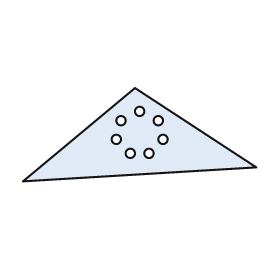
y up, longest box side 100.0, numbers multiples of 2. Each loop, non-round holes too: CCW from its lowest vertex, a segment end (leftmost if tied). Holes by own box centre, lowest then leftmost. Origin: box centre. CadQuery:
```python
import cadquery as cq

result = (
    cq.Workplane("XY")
    .moveTo(-50.0, -20.0)
    .lineTo(50.0, -14.0)
    .lineTo(-2.0, 20.0)
    .close()
    .moveTo(-4.0, -8.0)
    .circle(2.0)
    .moveTo(4.0, -8.0)
    .circle(2.0)
    .moveTo(-10.0, -2.0)
    .circle(2.0)
    .moveTo(10.0, -2.0)
    .circle(2.0)
    .moveTo(-8.0, 6.0)
    .circle(2.0)
    .moveTo(8.0, 6.0)
    .circle(2.0)
    .moveTo(0.0, 10.0)
    .circle(2.0)
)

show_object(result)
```